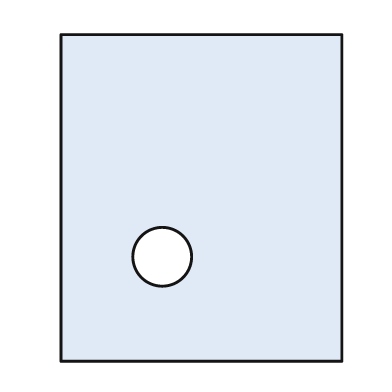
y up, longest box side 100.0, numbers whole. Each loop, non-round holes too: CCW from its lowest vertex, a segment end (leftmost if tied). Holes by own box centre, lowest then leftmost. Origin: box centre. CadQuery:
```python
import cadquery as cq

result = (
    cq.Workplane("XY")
    .moveTo(-43.0, -50.0)
    .lineTo(43.0, -50.0)
    .lineTo(43.0, 50.0)
    .lineTo(-43.0, 50.0)
    .close()
    .moveTo(-12.0, -18.0)
    .circle(9.0)
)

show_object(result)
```